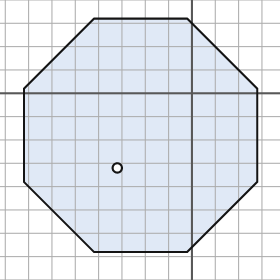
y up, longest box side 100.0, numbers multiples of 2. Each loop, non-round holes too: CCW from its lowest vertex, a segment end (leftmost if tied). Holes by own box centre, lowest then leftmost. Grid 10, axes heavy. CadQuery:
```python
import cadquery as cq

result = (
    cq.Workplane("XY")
    .moveTo(-42.0, -68.0)
    .lineTo(-2.0, -68.0)
    .lineTo(28.0, -38.0)
    .lineTo(28.0, 2.0)
    .lineTo(-2.0, 32.0)
    .lineTo(-42.0, 32.0)
    .lineTo(-72.0, 2.0)
    .lineTo(-72.0, -38.0)
    .close()
    .moveTo(-32.0, -32.0)
    .circle(2.0)
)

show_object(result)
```